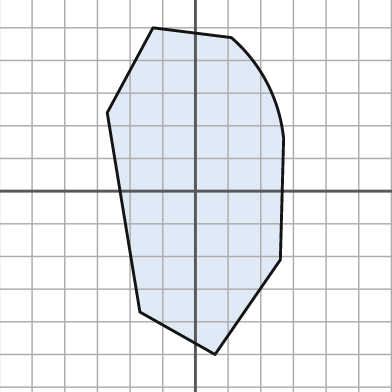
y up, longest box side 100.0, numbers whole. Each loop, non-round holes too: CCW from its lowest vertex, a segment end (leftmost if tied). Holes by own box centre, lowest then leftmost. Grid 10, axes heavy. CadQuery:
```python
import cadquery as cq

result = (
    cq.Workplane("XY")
    .moveTo(6.0, -50.0)
    .lineTo(26.0, -21.0)
    .lineTo(27.0, 16.0)
    .threePointArc((22.0, 33.0), (11.0, 47.0))
    .lineTo(-13.0, 50.0)
    .lineTo(-27.0, 24.0)
    .lineTo(-17.0, -37.0)
    .close()
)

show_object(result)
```